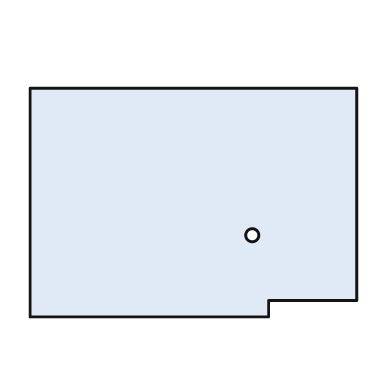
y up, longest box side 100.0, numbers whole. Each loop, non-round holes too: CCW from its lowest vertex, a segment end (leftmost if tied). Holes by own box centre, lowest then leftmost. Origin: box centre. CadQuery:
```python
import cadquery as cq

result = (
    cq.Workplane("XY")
    .moveTo(-50.0, -35.0)
    .lineTo(23.0, -35.0)
    .lineTo(23.0, -30.0)
    .lineTo(50.0, -30.0)
    .lineTo(50.0, 35.0)
    .lineTo(-50.0, 35.0)
    .close()
    .moveTo(18.0, -10.0)
    .circle(2.0)
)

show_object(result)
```